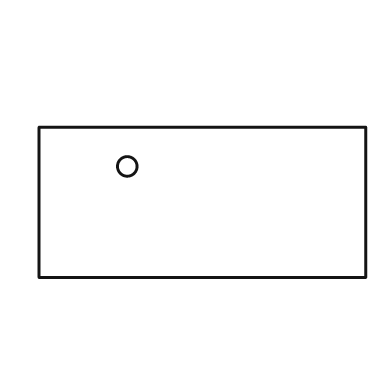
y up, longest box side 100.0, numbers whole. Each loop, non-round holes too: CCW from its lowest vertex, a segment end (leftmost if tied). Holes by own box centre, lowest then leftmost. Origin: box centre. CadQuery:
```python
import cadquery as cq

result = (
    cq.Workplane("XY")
    .moveTo(-50.0, -23.0)
    .lineTo(50.0, -23.0)
    .lineTo(50.0, 23.0)
    .lineTo(-50.0, 23.0)
    .close()
    .moveTo(-23.0, 11.0)
    .circle(3.0)
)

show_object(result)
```